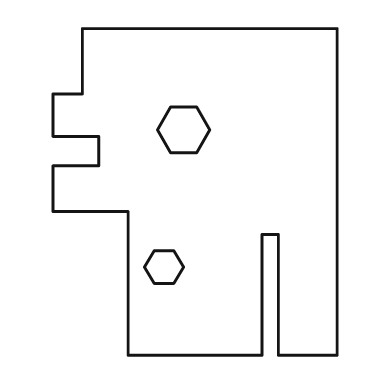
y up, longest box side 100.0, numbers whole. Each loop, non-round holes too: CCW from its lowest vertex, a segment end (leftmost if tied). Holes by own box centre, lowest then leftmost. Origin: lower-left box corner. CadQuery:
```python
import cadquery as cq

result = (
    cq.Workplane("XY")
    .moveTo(23.0, 0.0)
    .lineTo(64.0, 0.0)
    .lineTo(64.0, 37.0)
    .lineTo(69.0, 37.0)
    .lineTo(69.0, 0.0)
    .lineTo(87.0, 0.0)
    .lineTo(87.0, 100.0)
    .lineTo(9.0, 100.0)
    .lineTo(9.0, 80.0)
    .lineTo(0.0, 80.0)
    .lineTo(0.0, 67.0)
    .lineTo(14.0, 67.0)
    .lineTo(14.0, 58.0)
    .lineTo(0.0, 58.0)
    .lineTo(0.0, 44.0)
    .lineTo(23.0, 44.0)
    .close()
    .moveTo(31.0, 22.0)
    .lineTo(37.0, 22.0)
    .lineTo(40.0, 27.0)
    .lineTo(37.0, 32.0)
    .lineTo(31.0, 32.0)
    .lineTo(28.0, 27.0)
    .close()
    .moveTo(36.0, 62.0)
    .lineTo(44.0, 62.0)
    .lineTo(48.0, 69.0)
    .lineTo(44.0, 76.0)
    .lineTo(36.0, 76.0)
    .lineTo(32.0, 69.0)
    .close()
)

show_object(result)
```